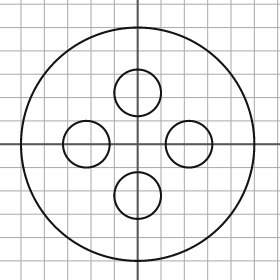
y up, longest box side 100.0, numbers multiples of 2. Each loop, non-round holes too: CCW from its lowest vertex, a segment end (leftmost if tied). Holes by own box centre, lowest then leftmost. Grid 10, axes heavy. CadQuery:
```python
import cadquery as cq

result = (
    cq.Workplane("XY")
    .moveTo(0.0, 0.0)
    .circle(50.0)
    .moveTo(0.0, -22.0)
    .circle(10.0)
    .moveTo(-22.0, 0.0)
    .circle(10.0)
    .moveTo(22.0, 0.0)
    .circle(10.0)
    .moveTo(0.0, 22.0)
    .circle(10.0)
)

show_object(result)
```